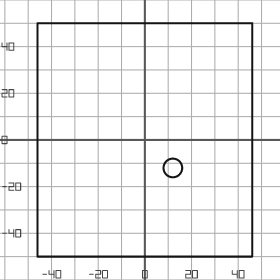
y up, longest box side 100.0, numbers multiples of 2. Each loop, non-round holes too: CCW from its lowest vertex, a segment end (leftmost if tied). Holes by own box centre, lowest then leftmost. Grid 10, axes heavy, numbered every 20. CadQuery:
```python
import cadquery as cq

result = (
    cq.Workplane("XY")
    .moveTo(-46.0, -50.0)
    .lineTo(46.0, -50.0)
    .lineTo(46.0, 50.0)
    .lineTo(-46.0, 50.0)
    .close()
    .moveTo(12.0, -12.0)
    .circle(4.0)
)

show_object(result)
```